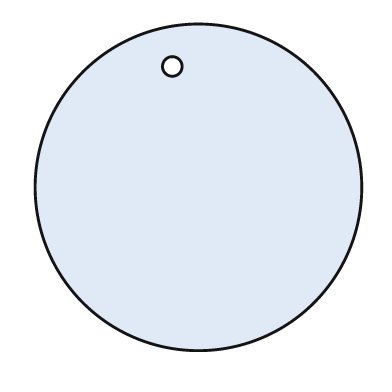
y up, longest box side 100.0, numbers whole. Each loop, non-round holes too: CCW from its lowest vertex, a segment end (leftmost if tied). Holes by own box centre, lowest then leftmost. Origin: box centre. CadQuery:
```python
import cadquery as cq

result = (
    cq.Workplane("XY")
    .moveTo(0.0, 0.0)
    .circle(50.0)
    .moveTo(-8.0, 37.0)
    .circle(3.0)
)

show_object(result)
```